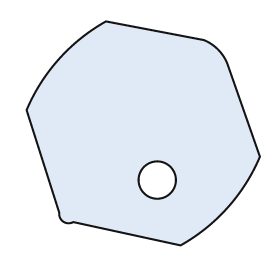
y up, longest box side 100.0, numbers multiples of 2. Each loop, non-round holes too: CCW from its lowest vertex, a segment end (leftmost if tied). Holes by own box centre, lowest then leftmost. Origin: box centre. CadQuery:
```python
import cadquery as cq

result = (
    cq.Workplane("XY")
    .moveTo(16.0, -48.0)
    .threePointArc((36.0, -32.0), (50.0, -10.0))
    .lineTo(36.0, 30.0)
    .threePointArc((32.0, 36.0), (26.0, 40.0))
    .lineTo(-16.0, 48.0)
    .threePointArc((-36.0, 32.0), (-50.0, 10.0))
    .lineTo(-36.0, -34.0)
    .threePointArc((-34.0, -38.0), (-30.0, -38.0))
    .close()
    .moveTo(6.0, -20.0)
    .circle(8.0)
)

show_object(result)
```